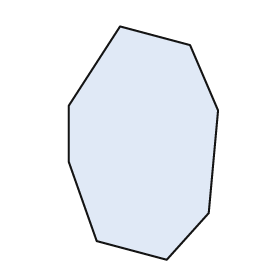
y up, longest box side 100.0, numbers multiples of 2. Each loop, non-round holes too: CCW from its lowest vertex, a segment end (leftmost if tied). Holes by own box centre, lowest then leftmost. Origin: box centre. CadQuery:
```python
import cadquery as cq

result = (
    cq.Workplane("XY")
    .moveTo(10.0, -50.0)
    .lineTo(28.0, -30.0)
    .lineTo(32.0, 14.0)
    .lineTo(20.0, 42.0)
    .lineTo(-10.0, 50.0)
    .lineTo(-32.0, 16.0)
    .lineTo(-32.0, -8.0)
    .lineTo(-20.0, -42.0)
    .close()
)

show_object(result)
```